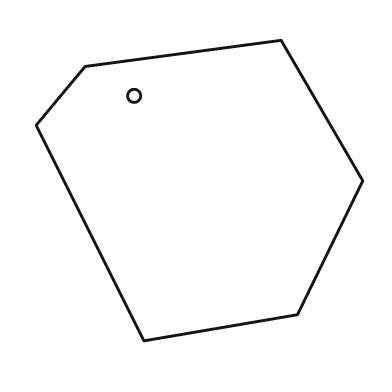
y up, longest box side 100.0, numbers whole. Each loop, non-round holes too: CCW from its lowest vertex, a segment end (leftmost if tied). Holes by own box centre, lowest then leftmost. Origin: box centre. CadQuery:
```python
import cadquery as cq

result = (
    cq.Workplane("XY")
    .moveTo(-17.0, -46.0)
    .lineTo(30.0, -38.0)
    .lineTo(50.0, 3.0)
    .lineTo(25.0, 46.0)
    .lineTo(-35.0, 38.0)
    .lineTo(-50.0, 20.0)
    .close()
    .moveTo(-20.0, 29.0)
    .circle(2.0)
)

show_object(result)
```